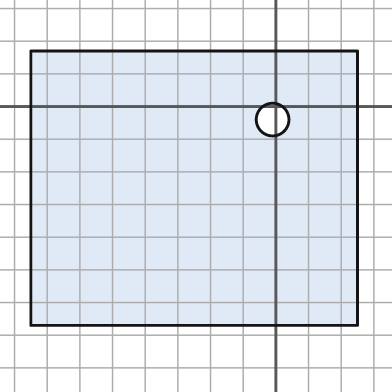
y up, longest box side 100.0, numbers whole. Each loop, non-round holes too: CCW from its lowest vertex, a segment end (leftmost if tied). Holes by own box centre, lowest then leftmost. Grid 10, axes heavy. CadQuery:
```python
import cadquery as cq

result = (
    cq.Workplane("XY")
    .moveTo(-75.0, -67.0)
    .lineTo(25.0, -67.0)
    .lineTo(25.0, 17.0)
    .lineTo(-75.0, 17.0)
    .close()
    .moveTo(-1.0, -4.0)
    .circle(5.0)
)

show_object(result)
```